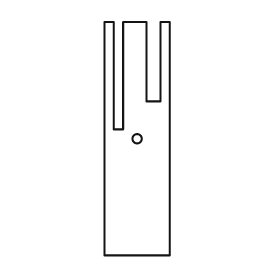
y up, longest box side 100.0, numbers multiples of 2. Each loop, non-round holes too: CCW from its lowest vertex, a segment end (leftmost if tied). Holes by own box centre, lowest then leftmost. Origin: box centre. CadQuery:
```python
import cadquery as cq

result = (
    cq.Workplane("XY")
    .moveTo(-14.0, -50.0)
    .lineTo(14.0, -50.0)
    .lineTo(14.0, 50.0)
    .lineTo(10.0, 50.0)
    .lineTo(10.0, 16.0)
    .lineTo(4.0, 16.0)
    .lineTo(4.0, 50.0)
    .lineTo(-6.0, 50.0)
    .lineTo(-6.0, 4.0)
    .lineTo(-10.0, 4.0)
    .lineTo(-10.0, 50.0)
    .lineTo(-14.0, 50.0)
    .close()
    .moveTo(0.0, 0.0)
    .circle(2.0)
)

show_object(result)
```